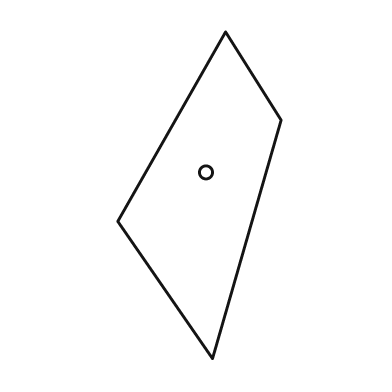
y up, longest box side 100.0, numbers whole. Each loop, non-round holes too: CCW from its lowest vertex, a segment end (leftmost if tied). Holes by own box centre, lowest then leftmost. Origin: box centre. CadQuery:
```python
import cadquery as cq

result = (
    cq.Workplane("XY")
    .moveTo(4.0, -50.0)
    .lineTo(25.0, 23.0)
    .lineTo(8.0, 50.0)
    .lineTo(-25.0, -8.0)
    .close()
    .moveTo(2.0, 7.0)
    .circle(2.0)
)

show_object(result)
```